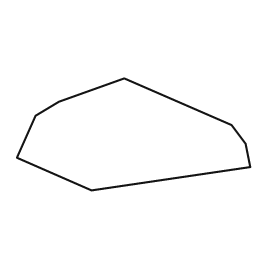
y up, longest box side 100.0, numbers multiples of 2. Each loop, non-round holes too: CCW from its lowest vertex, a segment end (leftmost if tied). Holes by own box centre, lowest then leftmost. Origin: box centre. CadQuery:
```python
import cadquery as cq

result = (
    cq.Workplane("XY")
    .moveTo(-18.0, -24.0)
    .lineTo(50.0, -14.0)
    .lineTo(48.0, -4.0)
    .lineTo(42.0, 4.0)
    .lineTo(-4.0, 24.0)
    .lineTo(-32.0, 14.0)
    .lineTo(-42.0, 8.0)
    .lineTo(-50.0, -10.0)
    .close()
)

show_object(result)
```